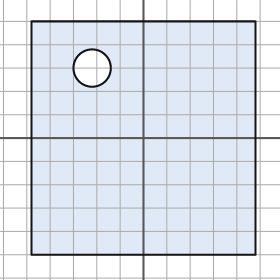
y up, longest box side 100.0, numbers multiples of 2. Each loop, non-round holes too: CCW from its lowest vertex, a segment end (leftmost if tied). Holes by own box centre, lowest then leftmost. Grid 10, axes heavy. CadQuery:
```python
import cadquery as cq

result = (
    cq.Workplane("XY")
    .moveTo(-48.0, -50.0)
    .lineTo(48.0, -50.0)
    .lineTo(48.0, 50.0)
    .lineTo(-48.0, 50.0)
    .close()
    .moveTo(-22.0, 30.0)
    .circle(8.0)
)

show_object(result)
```